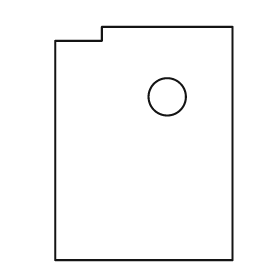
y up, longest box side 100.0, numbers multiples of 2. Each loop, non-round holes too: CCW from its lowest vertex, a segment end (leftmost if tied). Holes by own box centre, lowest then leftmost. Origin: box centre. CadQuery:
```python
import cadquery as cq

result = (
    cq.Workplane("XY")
    .moveTo(-38.0, -50.0)
    .lineTo(38.0, -50.0)
    .lineTo(38.0, 50.0)
    .lineTo(-18.0, 50.0)
    .lineTo(-18.0, 44.0)
    .lineTo(-38.0, 44.0)
    .close()
    .moveTo(10.0, 20.0)
    .circle(8.0)
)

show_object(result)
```